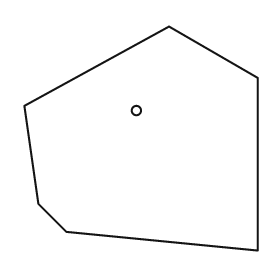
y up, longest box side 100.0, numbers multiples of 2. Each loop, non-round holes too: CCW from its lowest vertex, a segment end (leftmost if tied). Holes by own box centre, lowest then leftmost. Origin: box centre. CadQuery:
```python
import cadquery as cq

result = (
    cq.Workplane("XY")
    .moveTo(50.0, -48.0)
    .lineTo(50.0, 26.0)
    .lineTo(12.0, 48.0)
    .lineTo(-50.0, 14.0)
    .lineTo(-44.0, -28.0)
    .lineTo(-32.0, -40.0)
    .close()
    .moveTo(-2.0, 12.0)
    .circle(2.0)
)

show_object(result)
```